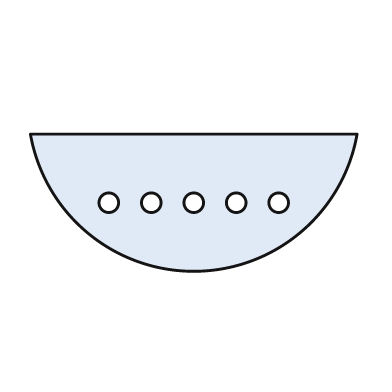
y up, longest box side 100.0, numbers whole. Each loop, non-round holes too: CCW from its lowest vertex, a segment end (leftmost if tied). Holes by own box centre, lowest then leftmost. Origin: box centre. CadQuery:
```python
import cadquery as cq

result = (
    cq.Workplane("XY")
    .moveTo(-50.0, 21.0)
    .threePointArc((0.0, -21.0), (50.0, 21.0))
    .close()
    .moveTo(-26.0, 0.0)
    .circle(3.0)
    .moveTo(-13.0, 0.0)
    .circle(3.0)
    .moveTo(0.0, 0.0)
    .circle(3.0)
    .moveTo(13.0, 0.0)
    .circle(3.0)
    .moveTo(26.0, 0.0)
    .circle(3.0)
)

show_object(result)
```